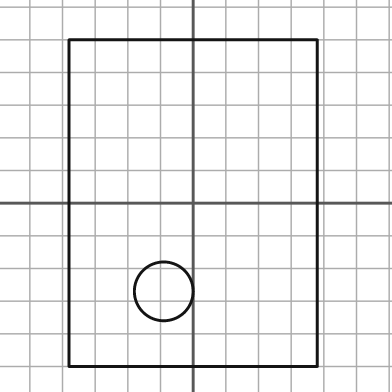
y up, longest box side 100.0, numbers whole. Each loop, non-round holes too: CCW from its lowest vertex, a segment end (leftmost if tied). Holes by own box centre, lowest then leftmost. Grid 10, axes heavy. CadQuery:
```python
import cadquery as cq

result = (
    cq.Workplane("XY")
    .moveTo(-38.0, -50.0)
    .lineTo(38.0, -50.0)
    .lineTo(38.0, 50.0)
    .lineTo(-38.0, 50.0)
    .close()
    .moveTo(-9.0, -27.0)
    .circle(9.0)
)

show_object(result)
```